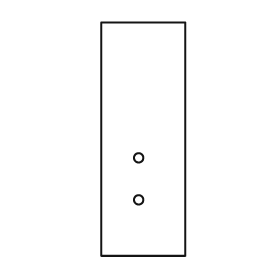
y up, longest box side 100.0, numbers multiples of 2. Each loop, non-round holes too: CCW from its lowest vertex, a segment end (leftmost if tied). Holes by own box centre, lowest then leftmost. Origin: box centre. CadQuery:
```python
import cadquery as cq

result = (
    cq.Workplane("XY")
    .moveTo(-18.0, -50.0)
    .lineTo(18.0, -50.0)
    .lineTo(18.0, 50.0)
    .lineTo(-18.0, 50.0)
    .close()
    .moveTo(-2.0, -26.0)
    .circle(2.0)
    .moveTo(-2.0, -8.0)
    .circle(2.0)
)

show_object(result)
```